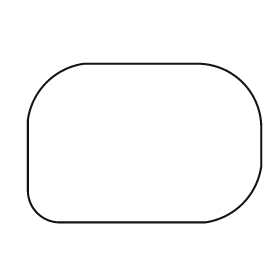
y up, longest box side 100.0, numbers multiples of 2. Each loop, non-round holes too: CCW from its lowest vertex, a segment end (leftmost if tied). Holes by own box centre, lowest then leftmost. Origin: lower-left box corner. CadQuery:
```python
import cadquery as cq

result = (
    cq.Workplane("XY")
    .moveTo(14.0, 0.0)
    .lineTo(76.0, 0.0)
    .threePointArc((92.0, 8.0), (100.0, 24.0))
    .lineTo(100.0, 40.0)
    .threePointArc((92.0, 60.0), (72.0, 68.0))
    .lineTo(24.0, 68.0)
    .threePointArc((8.0, 60.0), (0.0, 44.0))
    .lineTo(0.0, 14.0)
    .threePointArc((4.0, 4.0), (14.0, 0.0))
    .close()
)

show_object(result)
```